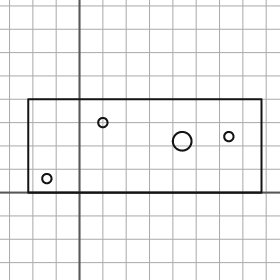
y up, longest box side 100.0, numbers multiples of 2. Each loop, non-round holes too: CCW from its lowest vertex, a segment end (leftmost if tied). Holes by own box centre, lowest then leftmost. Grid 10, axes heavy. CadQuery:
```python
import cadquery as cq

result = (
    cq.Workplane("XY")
    .moveTo(-22.0, 0.0)
    .lineTo(78.0, 0.0)
    .lineTo(78.0, 40.0)
    .lineTo(-22.0, 40.0)
    .close()
    .moveTo(-14.0, 6.0)
    .circle(2.0)
    .moveTo(44.0, 22.0)
    .circle(4.0)
    .moveTo(64.0, 24.0)
    .circle(2.0)
    .moveTo(10.0, 30.0)
    .circle(2.0)
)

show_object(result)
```